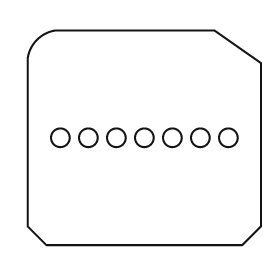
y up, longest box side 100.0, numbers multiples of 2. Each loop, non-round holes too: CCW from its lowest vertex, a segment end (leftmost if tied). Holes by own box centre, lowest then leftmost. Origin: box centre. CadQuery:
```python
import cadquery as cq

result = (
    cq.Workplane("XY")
    .moveTo(-42.0, -46.0)
    .lineTo(42.0, -46.0)
    .lineTo(50.0, -38.0)
    .lineTo(50.0, 32.0)
    .lineTo(30.0, 46.0)
    .lineTo(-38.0, 46.0)
    .threePointArc((-46.0, 42.0), (-50.0, 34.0))
    .lineTo(-50.0, -38.0)
    .close()
    .moveTo(-36.0, 0.0)
    .circle(4.0)
    .moveTo(-24.0, 0.0)
    .circle(4.0)
    .moveTo(-12.0, 0.0)
    .circle(4.0)
    .moveTo(0.0, 0.0)
    .circle(4.0)
    .moveTo(12.0, 0.0)
    .circle(4.0)
    .moveTo(24.0, 0.0)
    .circle(4.0)
    .moveTo(36.0, 0.0)
    .circle(4.0)
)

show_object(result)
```